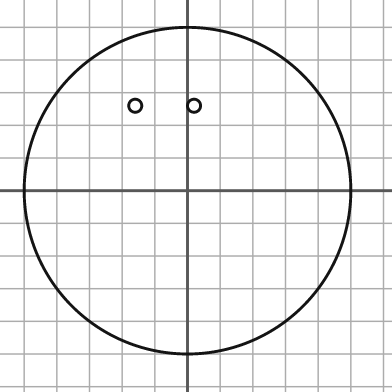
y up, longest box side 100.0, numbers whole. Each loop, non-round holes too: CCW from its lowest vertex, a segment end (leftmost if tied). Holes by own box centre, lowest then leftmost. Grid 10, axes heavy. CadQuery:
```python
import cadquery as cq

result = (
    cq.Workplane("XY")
    .moveTo(0.0, 0.0)
    .circle(50.0)
    .moveTo(-16.0, 26.0)
    .circle(2.0)
    .moveTo(2.0, 26.0)
    .circle(2.0)
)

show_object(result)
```